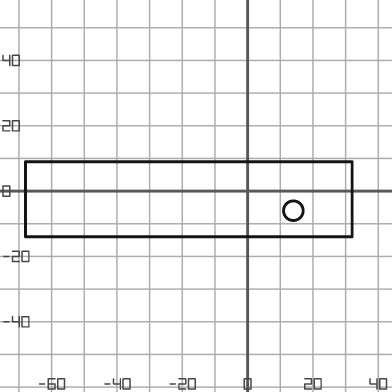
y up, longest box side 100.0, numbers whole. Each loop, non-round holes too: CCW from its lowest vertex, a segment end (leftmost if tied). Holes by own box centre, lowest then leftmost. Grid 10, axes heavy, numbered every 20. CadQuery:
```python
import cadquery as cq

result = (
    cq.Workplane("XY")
    .moveTo(-68.0, -14.0)
    .lineTo(32.0, -14.0)
    .lineTo(32.0, 9.0)
    .lineTo(-68.0, 9.0)
    .close()
    .moveTo(14.0, -6.0)
    .circle(3.0)
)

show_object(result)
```